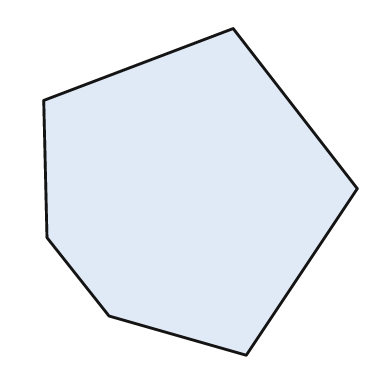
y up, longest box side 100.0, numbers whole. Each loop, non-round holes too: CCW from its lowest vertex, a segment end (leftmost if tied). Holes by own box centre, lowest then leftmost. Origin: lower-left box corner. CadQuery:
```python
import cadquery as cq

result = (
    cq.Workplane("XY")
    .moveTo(62.0, 0.0)
    .lineTo(96.0, 51.0)
    .lineTo(58.0, 100.0)
    .lineTo(0.0, 78.0)
    .lineTo(1.0, 36.0)
    .lineTo(20.0, 12.0)
    .close()
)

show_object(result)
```